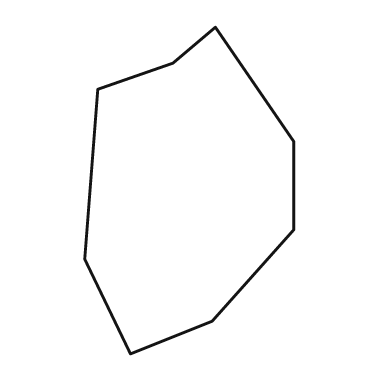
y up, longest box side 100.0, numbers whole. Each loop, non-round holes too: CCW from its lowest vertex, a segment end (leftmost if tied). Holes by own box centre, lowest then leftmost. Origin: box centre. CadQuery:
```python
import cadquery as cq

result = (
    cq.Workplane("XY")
    .moveTo(-18.0, -50.0)
    .lineTo(7.0, -40.0)
    .lineTo(32.0, -12.0)
    .lineTo(32.0, 15.0)
    .lineTo(8.0, 50.0)
    .lineTo(-5.0, 39.0)
    .lineTo(-28.0, 31.0)
    .lineTo(-32.0, -21.0)
    .close()
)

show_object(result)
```